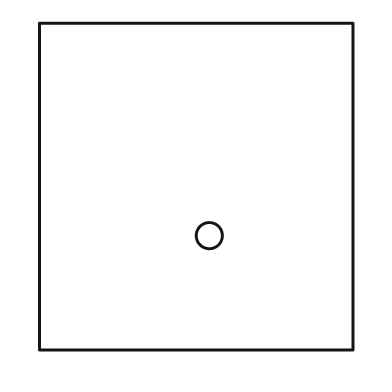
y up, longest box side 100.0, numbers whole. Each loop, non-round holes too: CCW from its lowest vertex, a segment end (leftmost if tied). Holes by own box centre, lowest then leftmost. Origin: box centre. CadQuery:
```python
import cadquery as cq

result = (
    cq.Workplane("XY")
    .moveTo(-48.0, -50.0)
    .lineTo(48.0, -50.0)
    .lineTo(48.0, 50.0)
    .lineTo(-48.0, 50.0)
    .close()
    .moveTo(4.0, -15.0)
    .circle(4.0)
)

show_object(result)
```